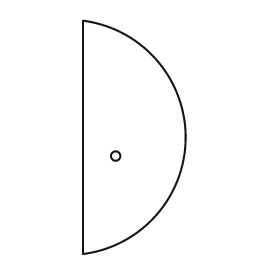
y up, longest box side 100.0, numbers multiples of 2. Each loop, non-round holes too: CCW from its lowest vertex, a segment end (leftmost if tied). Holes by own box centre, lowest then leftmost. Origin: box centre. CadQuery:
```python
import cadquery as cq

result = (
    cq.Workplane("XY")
    .moveTo(-22.0, -50.0)
    .threePointArc((22.0, 0.0), (-22.0, 50.0))
    .close()
    .moveTo(-8.0, -8.0)
    .circle(2.0)
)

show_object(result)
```